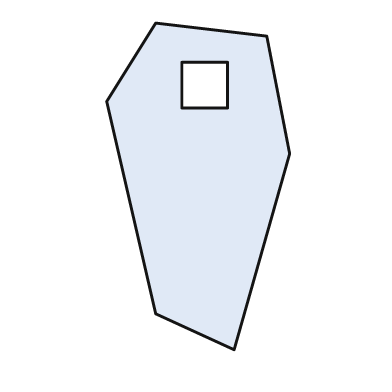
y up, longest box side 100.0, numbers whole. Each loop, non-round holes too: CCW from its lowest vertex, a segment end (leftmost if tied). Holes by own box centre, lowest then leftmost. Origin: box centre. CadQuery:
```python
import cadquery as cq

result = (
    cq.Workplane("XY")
    .moveTo(11.0, -50.0)
    .lineTo(28.0, 10.0)
    .lineTo(21.0, 46.0)
    .lineTo(-13.0, 50.0)
    .lineTo(-28.0, 26.0)
    .lineTo(-13.0, -39.0)
    .close()
    .moveTo(-5.0, 24.0)
    .lineTo(9.0, 24.0)
    .lineTo(9.0, 38.0)
    .lineTo(-5.0, 38.0)
    .close()
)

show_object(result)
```